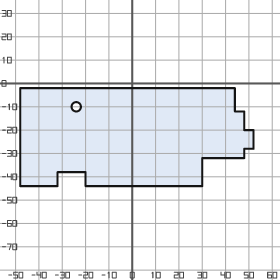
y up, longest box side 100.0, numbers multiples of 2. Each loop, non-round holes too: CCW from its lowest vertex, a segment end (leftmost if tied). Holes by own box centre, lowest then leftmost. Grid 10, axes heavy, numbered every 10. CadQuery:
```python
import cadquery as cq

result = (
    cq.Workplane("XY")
    .moveTo(-48.0, -44.0)
    .lineTo(-32.0, -44.0)
    .lineTo(-32.0, -38.0)
    .lineTo(-20.0, -38.0)
    .lineTo(-20.0, -44.0)
    .lineTo(30.0, -44.0)
    .lineTo(30.0, -32.0)
    .lineTo(48.0, -32.0)
    .lineTo(48.0, -28.0)
    .lineTo(52.0, -28.0)
    .lineTo(52.0, -20.0)
    .lineTo(48.0, -20.0)
    .lineTo(48.0, -12.0)
    .lineTo(44.0, -12.0)
    .lineTo(44.0, -2.0)
    .lineTo(-48.0, -2.0)
    .close()
    .moveTo(-24.0, -10.0)
    .circle(2.0)
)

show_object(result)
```